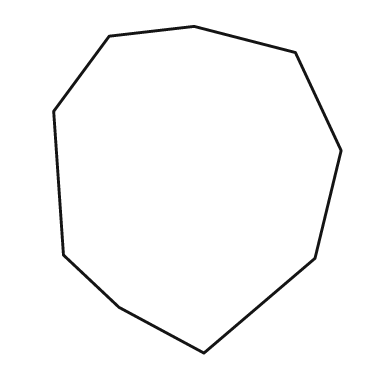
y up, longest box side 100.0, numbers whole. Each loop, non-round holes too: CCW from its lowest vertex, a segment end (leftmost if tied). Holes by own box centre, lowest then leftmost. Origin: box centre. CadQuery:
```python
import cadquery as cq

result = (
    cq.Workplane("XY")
    .moveTo(2.0, -50.0)
    .lineTo(36.0, -21.0)
    .lineTo(44.0, 12.0)
    .lineTo(30.0, 42.0)
    .lineTo(-1.0, 50.0)
    .lineTo(-27.0, 47.0)
    .lineTo(-44.0, 24.0)
    .lineTo(-41.0, -20.0)
    .lineTo(-24.0, -36.0)
    .close()
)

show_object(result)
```